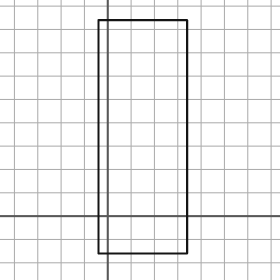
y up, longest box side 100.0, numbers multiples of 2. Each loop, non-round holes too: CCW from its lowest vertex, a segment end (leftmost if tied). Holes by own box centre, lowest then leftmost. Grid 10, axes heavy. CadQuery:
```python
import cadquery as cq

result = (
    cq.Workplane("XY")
    .moveTo(-4.0, -16.0)
    .lineTo(34.0, -16.0)
    .lineTo(34.0, 84.0)
    .lineTo(-4.0, 84.0)
    .close()
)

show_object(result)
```